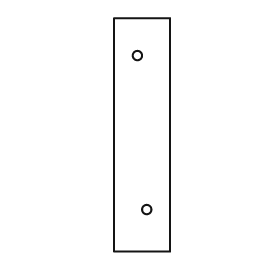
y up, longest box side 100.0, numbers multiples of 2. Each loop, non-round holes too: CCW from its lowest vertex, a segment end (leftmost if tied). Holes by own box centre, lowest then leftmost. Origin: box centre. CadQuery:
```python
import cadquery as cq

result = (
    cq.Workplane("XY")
    .moveTo(-12.0, -50.0)
    .lineTo(12.0, -50.0)
    .lineTo(12.0, 50.0)
    .lineTo(-12.0, 50.0)
    .close()
    .moveTo(2.0, -32.0)
    .circle(2.0)
    .moveTo(-2.0, 34.0)
    .circle(2.0)
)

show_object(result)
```